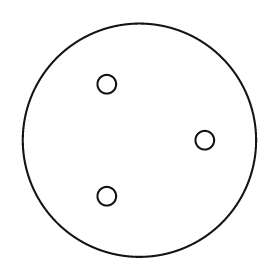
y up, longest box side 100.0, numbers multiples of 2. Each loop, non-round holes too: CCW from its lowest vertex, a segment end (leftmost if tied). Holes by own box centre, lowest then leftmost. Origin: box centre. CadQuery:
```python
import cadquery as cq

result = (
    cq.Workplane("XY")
    .moveTo(0.0, 0.0)
    .circle(50.0)
    .moveTo(-14.0, -24.0)
    .circle(4.0)
    .moveTo(28.0, 0.0)
    .circle(4.0)
    .moveTo(-14.0, 24.0)
    .circle(4.0)
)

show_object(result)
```